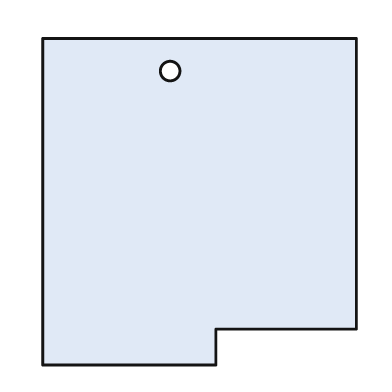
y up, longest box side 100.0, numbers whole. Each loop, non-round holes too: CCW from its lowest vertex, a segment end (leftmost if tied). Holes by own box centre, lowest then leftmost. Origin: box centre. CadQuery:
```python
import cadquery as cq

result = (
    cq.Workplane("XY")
    .moveTo(-48.0, -50.0)
    .lineTo(5.0, -50.0)
    .lineTo(5.0, -39.0)
    .lineTo(48.0, -39.0)
    .lineTo(48.0, 50.0)
    .lineTo(-48.0, 50.0)
    .close()
    .moveTo(-9.0, 40.0)
    .circle(3.0)
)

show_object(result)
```